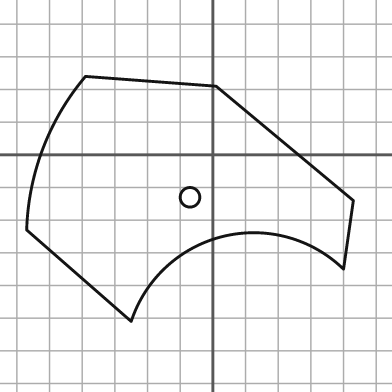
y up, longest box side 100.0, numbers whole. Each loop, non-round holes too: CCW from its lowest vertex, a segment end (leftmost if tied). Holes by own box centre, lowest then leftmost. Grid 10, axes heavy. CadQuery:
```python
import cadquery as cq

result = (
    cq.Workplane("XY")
    .moveTo(-25.0, -51.0)
    .threePointArc((3.0, -25.0), (40.0, -35.0))
    .lineTo(43.0, -14.0)
    .lineTo(1.0, 21.0)
    .lineTo(-39.0, 24.0)
    .threePointArc((-52.0, 2.0), (-57.0, -23.0))
    .close()
    .moveTo(-7.0, -13.0)
    .circle(3.0)
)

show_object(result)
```